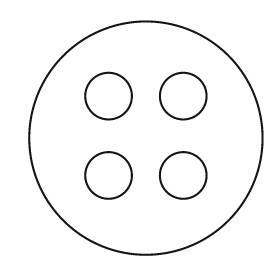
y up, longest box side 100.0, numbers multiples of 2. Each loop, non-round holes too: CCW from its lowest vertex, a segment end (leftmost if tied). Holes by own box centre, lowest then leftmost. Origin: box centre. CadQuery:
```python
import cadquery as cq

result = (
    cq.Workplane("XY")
    .moveTo(0.0, 0.0)
    .circle(50.0)
    .moveTo(-16.0, -16.0)
    .circle(10.0)
    .moveTo(16.0, -16.0)
    .circle(10.0)
    .moveTo(-16.0, 18.0)
    .circle(10.0)
    .moveTo(16.0, 18.0)
    .circle(10.0)
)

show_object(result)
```